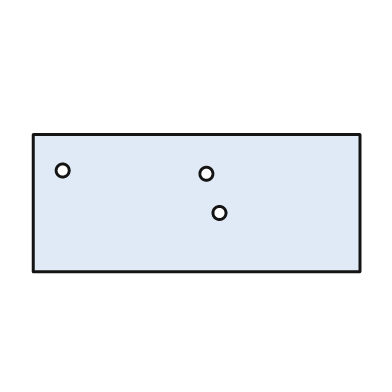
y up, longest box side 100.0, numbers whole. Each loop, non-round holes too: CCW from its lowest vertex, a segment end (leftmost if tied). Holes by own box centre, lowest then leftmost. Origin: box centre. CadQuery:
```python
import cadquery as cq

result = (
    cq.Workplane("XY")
    .moveTo(-50.0, -21.0)
    .lineTo(50.0, -21.0)
    .lineTo(50.0, 21.0)
    .lineTo(-50.0, 21.0)
    .close()
    .moveTo(7.0, -3.0)
    .circle(2.0)
    .moveTo(3.0, 9.0)
    .circle(2.0)
    .moveTo(-41.0, 10.0)
    .circle(2.0)
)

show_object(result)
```